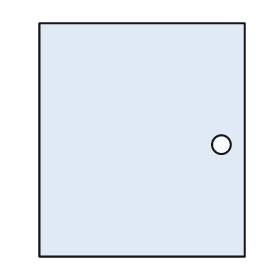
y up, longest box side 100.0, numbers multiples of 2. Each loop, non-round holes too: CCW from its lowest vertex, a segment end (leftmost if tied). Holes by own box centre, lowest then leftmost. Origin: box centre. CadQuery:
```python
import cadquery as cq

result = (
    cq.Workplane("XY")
    .moveTo(-44.0, -50.0)
    .lineTo(44.0, -50.0)
    .lineTo(44.0, 50.0)
    .lineTo(-44.0, 50.0)
    .close()
    .moveTo(34.0, -2.0)
    .circle(4.0)
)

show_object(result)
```